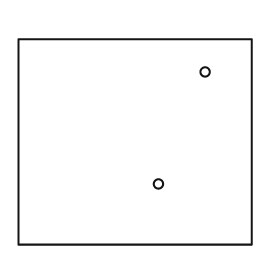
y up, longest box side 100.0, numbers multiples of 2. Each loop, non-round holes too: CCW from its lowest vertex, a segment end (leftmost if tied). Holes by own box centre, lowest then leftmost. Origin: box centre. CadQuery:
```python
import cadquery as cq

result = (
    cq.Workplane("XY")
    .moveTo(-50.0, -44.0)
    .lineTo(50.0, -44.0)
    .lineTo(50.0, 44.0)
    .lineTo(-50.0, 44.0)
    .close()
    .moveTo(10.0, -18.0)
    .circle(2.0)
    .moveTo(30.0, 30.0)
    .circle(2.0)
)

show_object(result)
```